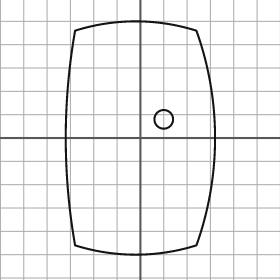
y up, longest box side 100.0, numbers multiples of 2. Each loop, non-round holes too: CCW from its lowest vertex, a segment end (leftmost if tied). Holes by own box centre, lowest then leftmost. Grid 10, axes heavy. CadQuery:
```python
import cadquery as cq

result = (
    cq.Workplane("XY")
    .moveTo(-28.0, -46.0)
    .threePointArc((-2.0, -50.0), (24.0, -46.0))
    .threePointArc((32.0, 0.0), (24.0, 46.0))
    .threePointArc((-2.0, 50.0), (-28.0, 46.0))
    .threePointArc((-32.0, 0.0), (-28.0, -46.0))
    .close()
    .moveTo(10.0, 8.0)
    .circle(4.0)
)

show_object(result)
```